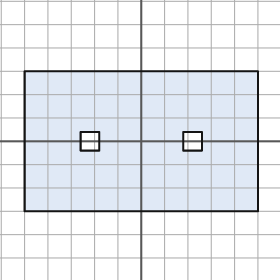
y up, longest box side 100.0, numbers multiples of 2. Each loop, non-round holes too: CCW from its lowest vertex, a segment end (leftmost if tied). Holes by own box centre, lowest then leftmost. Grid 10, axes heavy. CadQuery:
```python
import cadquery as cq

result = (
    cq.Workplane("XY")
    .moveTo(-50.0, -30.0)
    .lineTo(50.0, -30.0)
    .lineTo(50.0, 30.0)
    .lineTo(-50.0, 30.0)
    .close()
    .moveTo(-26.0, -4.0)
    .lineTo(-18.0, -4.0)
    .lineTo(-18.0, 4.0)
    .lineTo(-26.0, 4.0)
    .close()
    .moveTo(18.0, -4.0)
    .lineTo(26.0, -4.0)
    .lineTo(26.0, 4.0)
    .lineTo(18.0, 4.0)
    .close()
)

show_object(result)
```